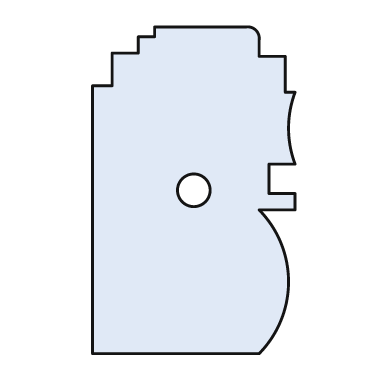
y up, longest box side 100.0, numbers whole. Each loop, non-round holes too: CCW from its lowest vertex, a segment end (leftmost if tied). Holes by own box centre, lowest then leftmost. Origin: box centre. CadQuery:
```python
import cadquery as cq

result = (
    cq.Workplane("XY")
    .moveTo(-31.0, -50.0)
    .lineTo(20.0, -50.0)
    .threePointArc((29.0, -28.0), (20.0, -6.0))
    .lineTo(31.0, -6.0)
    .lineTo(31.0, -1.0)
    .lineTo(23.0, -1.0)
    .lineTo(23.0, 8.0)
    .lineTo(31.0, 8.0)
    .threePointArc((29.0, 19.0), (31.0, 30.0))
    .lineTo(28.0, 30.0)
    .lineTo(28.0, 41.0)
    .lineTo(20.0, 41.0)
    .lineTo(20.0, 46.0)
    .threePointArc((19.0, 49.0), (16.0, 50.0))
    .lineTo(-12.0, 50.0)
    .lineTo(-12.0, 47.0)
    .lineTo(-17.0, 47.0)
    .lineTo(-17.0, 42.0)
    .lineTo(-25.0, 42.0)
    .lineTo(-25.0, 32.0)
    .lineTo(-31.0, 32.0)
    .close()
    .moveTo(0.0, 0.0)
    .circle(5.0)
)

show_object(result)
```